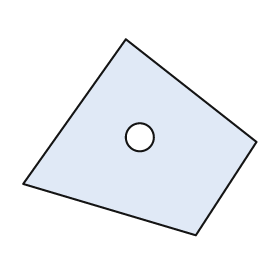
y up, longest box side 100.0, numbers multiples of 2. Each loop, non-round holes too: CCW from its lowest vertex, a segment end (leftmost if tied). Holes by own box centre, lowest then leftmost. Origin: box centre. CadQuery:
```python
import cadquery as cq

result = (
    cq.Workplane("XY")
    .moveTo(24.0, -42.0)
    .lineTo(50.0, -2.0)
    .lineTo(-6.0, 42.0)
    .lineTo(-50.0, -20.0)
    .close()
    .moveTo(0.0, 0.0)
    .circle(6.0)
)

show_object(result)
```